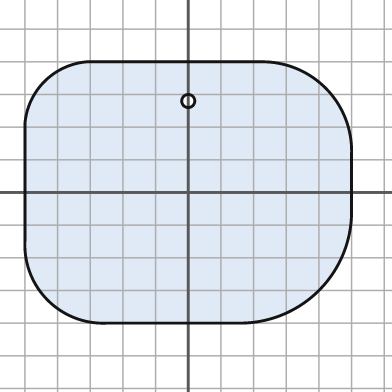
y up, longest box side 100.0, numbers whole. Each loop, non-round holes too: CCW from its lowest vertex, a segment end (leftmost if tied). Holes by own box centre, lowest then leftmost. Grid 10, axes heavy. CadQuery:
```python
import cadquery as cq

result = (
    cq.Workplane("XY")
    .moveTo(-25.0, -40.0)
    .lineTo(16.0, -40.0)
    .threePointArc((40.0, -30.0), (50.0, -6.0))
    .lineTo(50.0, 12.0)
    .threePointArc((42.0, 32.0), (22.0, 40.0))
    .lineTo(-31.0, 40.0)
    .threePointArc((-44.0, 34.0), (-50.0, 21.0))
    .lineTo(-50.0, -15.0)
    .threePointArc((-43.0, -33.0), (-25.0, -40.0))
    .close()
    .moveTo(0.0, 28.0)
    .circle(2.0)
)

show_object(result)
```